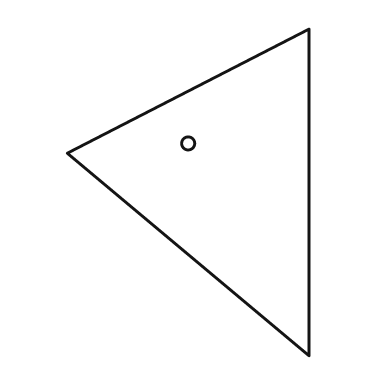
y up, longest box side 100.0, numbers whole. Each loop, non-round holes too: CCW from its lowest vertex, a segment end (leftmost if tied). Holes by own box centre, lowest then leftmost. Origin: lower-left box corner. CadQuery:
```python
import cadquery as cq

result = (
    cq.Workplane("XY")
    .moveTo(74.0, 0.0)
    .lineTo(74.0, 100.0)
    .lineTo(0.0, 62.0)
    .close()
    .moveTo(37.0, 65.0)
    .circle(2.0)
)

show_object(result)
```